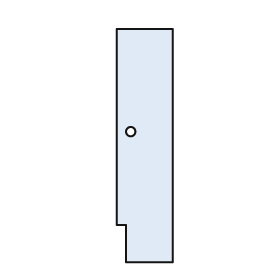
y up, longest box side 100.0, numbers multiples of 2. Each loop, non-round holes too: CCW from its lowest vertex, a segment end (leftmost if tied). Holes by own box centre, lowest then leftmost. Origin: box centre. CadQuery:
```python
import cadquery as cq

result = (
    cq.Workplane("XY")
    .moveTo(-8.0, -50.0)
    .lineTo(12.0, -50.0)
    .lineTo(12.0, 50.0)
    .lineTo(-12.0, 50.0)
    .lineTo(-12.0, -34.0)
    .lineTo(-8.0, -34.0)
    .close()
    .moveTo(-6.0, 6.0)
    .circle(2.0)
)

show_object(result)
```